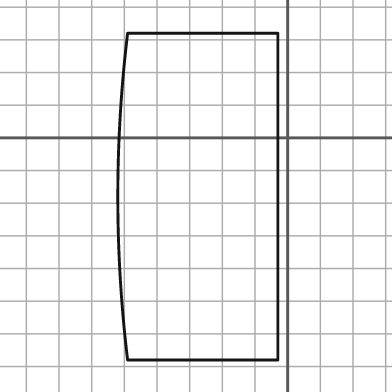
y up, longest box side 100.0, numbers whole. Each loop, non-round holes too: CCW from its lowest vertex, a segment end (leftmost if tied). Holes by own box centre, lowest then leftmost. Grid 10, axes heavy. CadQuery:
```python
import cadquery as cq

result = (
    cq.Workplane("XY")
    .moveTo(-49.0, -68.0)
    .lineTo(-3.0, -68.0)
    .lineTo(-3.0, 32.0)
    .lineTo(-49.0, 32.0)
    .threePointArc((-52.0, -18.0), (-49.0, -68.0))
    .close()
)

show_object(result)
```